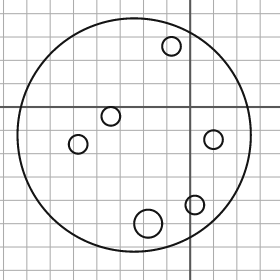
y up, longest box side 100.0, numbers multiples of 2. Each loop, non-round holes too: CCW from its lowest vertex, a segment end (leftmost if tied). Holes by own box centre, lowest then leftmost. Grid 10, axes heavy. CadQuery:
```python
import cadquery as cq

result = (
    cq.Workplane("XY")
    .moveTo(-24.0, -12.0)
    .circle(50.0)
    .moveTo(-18.0, -50.0)
    .circle(6.0)
    .moveTo(2.0, -42.0)
    .circle(4.0)
    .moveTo(-48.0, -16.0)
    .circle(4.0)
    .moveTo(10.0, -14.0)
    .circle(4.0)
    .moveTo(-34.0, -4.0)
    .circle(4.0)
    .moveTo(-8.0, 26.0)
    .circle(4.0)
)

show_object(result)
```